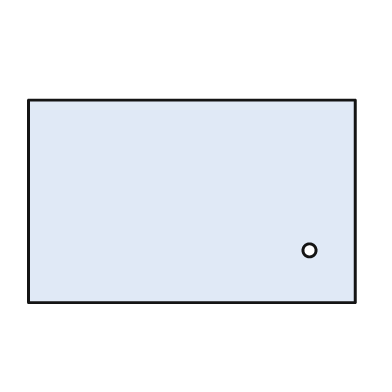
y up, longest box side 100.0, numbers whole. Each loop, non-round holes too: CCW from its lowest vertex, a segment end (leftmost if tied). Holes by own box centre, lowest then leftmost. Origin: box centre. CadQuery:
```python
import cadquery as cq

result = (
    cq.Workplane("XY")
    .moveTo(-50.0, -31.0)
    .lineTo(50.0, -31.0)
    .lineTo(50.0, 31.0)
    .lineTo(-50.0, 31.0)
    .close()
    .moveTo(36.0, -15.0)
    .circle(2.0)
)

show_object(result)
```